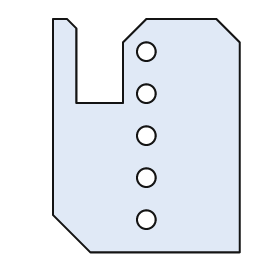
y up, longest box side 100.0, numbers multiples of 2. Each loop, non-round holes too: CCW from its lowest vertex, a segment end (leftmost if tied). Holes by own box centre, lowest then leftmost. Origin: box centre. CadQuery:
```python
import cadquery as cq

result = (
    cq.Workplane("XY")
    .moveTo(-24.0, -50.0)
    .lineTo(40.0, -50.0)
    .lineTo(40.0, 40.0)
    .lineTo(30.0, 50.0)
    .lineTo(0.0, 50.0)
    .lineTo(-10.0, 40.0)
    .lineTo(-10.0, 14.0)
    .lineTo(-30.0, 14.0)
    .lineTo(-30.0, 46.0)
    .lineTo(-34.0, 50.0)
    .lineTo(-40.0, 50.0)
    .lineTo(-40.0, -34.0)
    .close()
    .moveTo(0.0, -36.0)
    .circle(4.0)
    .moveTo(0.0, -18.0)
    .circle(4.0)
    .moveTo(0.0, 0.0)
    .circle(4.0)
    .moveTo(0.0, 18.0)
    .circle(4.0)
    .moveTo(0.0, 36.0)
    .circle(4.0)
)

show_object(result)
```